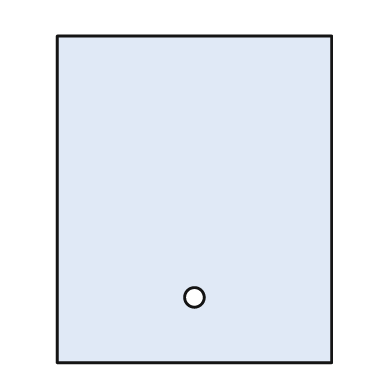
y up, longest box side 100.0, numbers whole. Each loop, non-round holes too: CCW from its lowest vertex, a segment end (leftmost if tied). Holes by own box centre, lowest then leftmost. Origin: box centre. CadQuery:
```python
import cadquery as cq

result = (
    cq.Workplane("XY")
    .moveTo(-42.0, -50.0)
    .lineTo(42.0, -50.0)
    .lineTo(42.0, 50.0)
    .lineTo(-42.0, 50.0)
    .close()
    .moveTo(0.0, -30.0)
    .circle(3.0)
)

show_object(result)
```